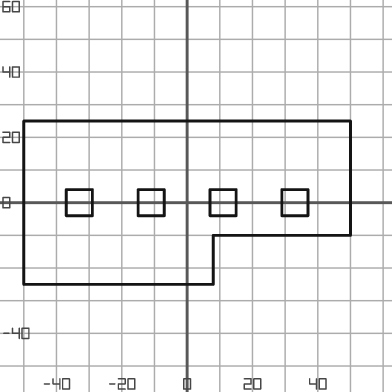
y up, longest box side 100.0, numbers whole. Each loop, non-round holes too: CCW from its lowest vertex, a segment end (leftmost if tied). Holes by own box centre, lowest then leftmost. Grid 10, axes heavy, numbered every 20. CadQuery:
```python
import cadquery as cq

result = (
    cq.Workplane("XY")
    .moveTo(-50.0, -25.0)
    .lineTo(8.0, -25.0)
    .lineTo(8.0, -10.0)
    .lineTo(50.0, -10.0)
    .lineTo(50.0, 25.0)
    .lineTo(-50.0, 25.0)
    .close()
    .moveTo(-37.0, -4.0)
    .lineTo(-29.0, -4.0)
    .lineTo(-29.0, 4.0)
    .lineTo(-37.0, 4.0)
    .close()
    .moveTo(-15.0, -4.0)
    .lineTo(-7.0, -4.0)
    .lineTo(-7.0, 4.0)
    .lineTo(-15.0, 4.0)
    .close()
    .moveTo(7.0, -4.0)
    .lineTo(15.0, -4.0)
    .lineTo(15.0, 4.0)
    .lineTo(7.0, 4.0)
    .close()
    .moveTo(29.0, -4.0)
    .lineTo(37.0, -4.0)
    .lineTo(37.0, 4.0)
    .lineTo(29.0, 4.0)
    .close()
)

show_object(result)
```